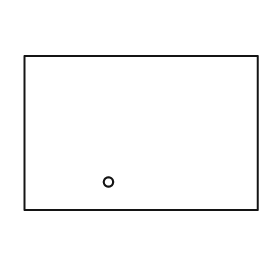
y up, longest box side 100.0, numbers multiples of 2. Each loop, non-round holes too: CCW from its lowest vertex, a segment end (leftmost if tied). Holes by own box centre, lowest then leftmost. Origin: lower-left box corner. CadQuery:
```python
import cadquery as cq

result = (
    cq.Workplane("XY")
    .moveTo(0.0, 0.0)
    .lineTo(100.0, 0.0)
    .lineTo(100.0, 66.0)
    .lineTo(0.0, 66.0)
    .close()
    .moveTo(36.0, 12.0)
    .circle(2.0)
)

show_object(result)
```